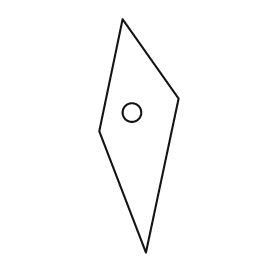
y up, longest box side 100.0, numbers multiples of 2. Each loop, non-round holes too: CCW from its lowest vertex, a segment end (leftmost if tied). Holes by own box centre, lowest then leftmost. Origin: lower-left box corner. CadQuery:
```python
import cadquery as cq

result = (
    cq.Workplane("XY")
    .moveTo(20.0, 0.0)
    .lineTo(34.0, 66.0)
    .lineTo(10.0, 100.0)
    .lineTo(0.0, 52.0)
    .close()
    .moveTo(14.0, 60.0)
    .circle(4.0)
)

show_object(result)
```